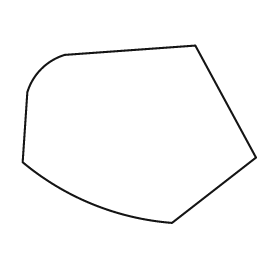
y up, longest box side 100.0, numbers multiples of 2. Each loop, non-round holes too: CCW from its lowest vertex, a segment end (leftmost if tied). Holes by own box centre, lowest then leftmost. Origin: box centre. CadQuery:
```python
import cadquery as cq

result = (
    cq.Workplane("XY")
    .moveTo(14.0, -38.0)
    .lineTo(50.0, -10.0)
    .lineTo(24.0, 38.0)
    .lineTo(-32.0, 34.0)
    .threePointArc((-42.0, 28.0), (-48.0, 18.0))
    .lineTo(-50.0, -12.0)
    .threePointArc((-20.0, -30.0), (14.0, -38.0))
    .close()
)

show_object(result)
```